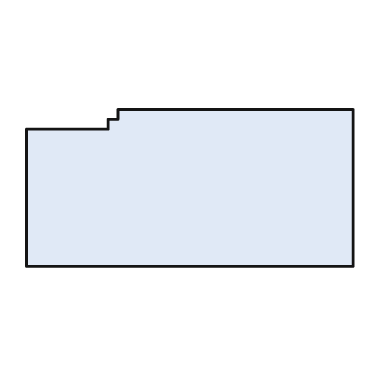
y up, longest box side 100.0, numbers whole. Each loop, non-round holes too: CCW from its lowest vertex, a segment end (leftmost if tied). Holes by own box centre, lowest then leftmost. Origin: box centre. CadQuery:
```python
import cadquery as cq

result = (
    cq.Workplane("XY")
    .moveTo(-50.0, -24.0)
    .lineTo(50.0, -24.0)
    .lineTo(50.0, 24.0)
    .lineTo(-22.0, 24.0)
    .lineTo(-22.0, 21.0)
    .lineTo(-25.0, 21.0)
    .lineTo(-25.0, 18.0)
    .lineTo(-50.0, 18.0)
    .close()
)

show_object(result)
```